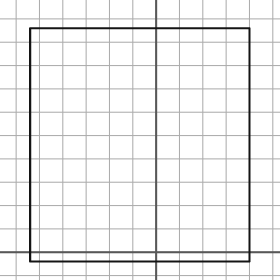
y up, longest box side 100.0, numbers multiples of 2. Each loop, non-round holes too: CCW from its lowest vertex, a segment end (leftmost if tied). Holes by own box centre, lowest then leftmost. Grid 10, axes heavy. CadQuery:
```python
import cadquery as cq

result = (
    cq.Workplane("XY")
    .moveTo(-54.0, -4.0)
    .lineTo(40.0, -4.0)
    .lineTo(40.0, 96.0)
    .lineTo(-54.0, 96.0)
    .close()
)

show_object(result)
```